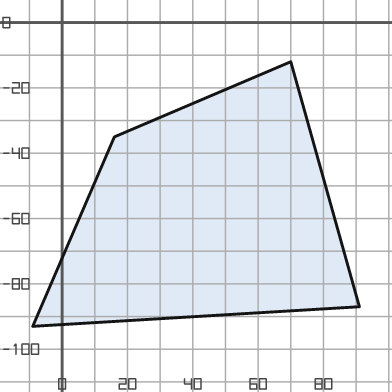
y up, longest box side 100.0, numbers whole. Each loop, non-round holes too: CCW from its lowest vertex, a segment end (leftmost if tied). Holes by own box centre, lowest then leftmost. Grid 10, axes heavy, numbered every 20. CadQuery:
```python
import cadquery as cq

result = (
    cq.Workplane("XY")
    .moveTo(-9.0, -93.0)
    .lineTo(91.0, -87.0)
    .lineTo(70.0, -12.0)
    .lineTo(16.0, -35.0)
    .close()
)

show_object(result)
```